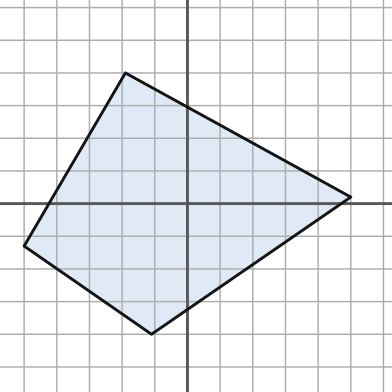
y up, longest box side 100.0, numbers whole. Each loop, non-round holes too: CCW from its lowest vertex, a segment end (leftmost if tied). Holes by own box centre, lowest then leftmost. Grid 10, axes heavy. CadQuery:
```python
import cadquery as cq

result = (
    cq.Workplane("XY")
    .moveTo(-11.0, -40.0)
    .lineTo(50.0, 2.0)
    .lineTo(-19.0, 40.0)
    .lineTo(-50.0, -13.0)
    .close()
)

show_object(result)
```